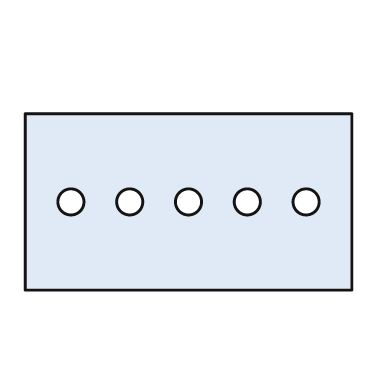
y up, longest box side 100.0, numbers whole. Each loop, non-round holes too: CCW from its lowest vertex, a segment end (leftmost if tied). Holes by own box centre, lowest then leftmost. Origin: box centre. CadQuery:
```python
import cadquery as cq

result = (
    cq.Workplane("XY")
    .moveTo(-50.0, -27.0)
    .lineTo(50.0, -27.0)
    .lineTo(50.0, 27.0)
    .lineTo(-50.0, 27.0)
    .close()
    .moveTo(-36.0, 0.0)
    .circle(4.0)
    .moveTo(-18.0, 0.0)
    .circle(4.0)
    .moveTo(0.0, 0.0)
    .circle(4.0)
    .moveTo(18.0, 0.0)
    .circle(4.0)
    .moveTo(36.0, 0.0)
    .circle(4.0)
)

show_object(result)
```